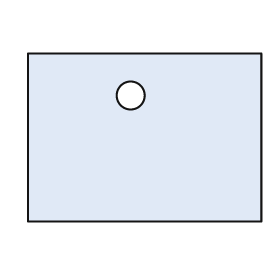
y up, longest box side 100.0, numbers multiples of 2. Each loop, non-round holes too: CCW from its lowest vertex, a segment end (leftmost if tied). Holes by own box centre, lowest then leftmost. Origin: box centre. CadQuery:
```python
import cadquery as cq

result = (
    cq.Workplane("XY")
    .moveTo(-50.0, -36.0)
    .lineTo(50.0, -36.0)
    .lineTo(50.0, 36.0)
    .lineTo(-50.0, 36.0)
    .close()
    .moveTo(-6.0, 18.0)
    .circle(6.0)
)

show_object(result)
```